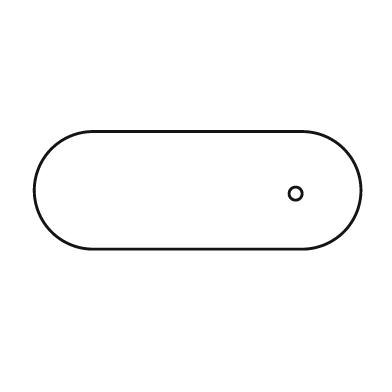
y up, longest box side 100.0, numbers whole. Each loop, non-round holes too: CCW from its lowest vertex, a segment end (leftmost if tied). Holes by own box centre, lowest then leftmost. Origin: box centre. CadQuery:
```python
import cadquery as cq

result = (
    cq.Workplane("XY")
    .moveTo(-32.0, -18.0)
    .lineTo(32.0, -18.0)
    .threePointArc((50.0, 0.0), (32.0, 18.0))
    .lineTo(-32.0, 18.0)
    .threePointArc((-50.0, 0.0), (-32.0, -18.0))
    .close()
    .moveTo(30.0, -1.0)
    .circle(2.0)
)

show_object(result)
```